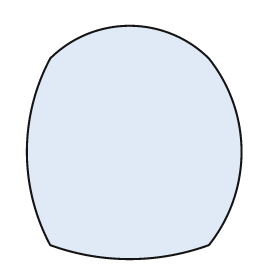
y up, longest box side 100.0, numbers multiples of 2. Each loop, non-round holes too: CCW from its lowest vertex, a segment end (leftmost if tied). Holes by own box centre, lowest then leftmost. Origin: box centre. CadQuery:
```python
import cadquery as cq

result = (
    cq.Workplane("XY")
    .moveTo(-36.0, -44.0)
    .threePointArc((-2.0, -50.0), (32.0, -44.0))
    .threePointArc((46.0, -4.0), (32.0, 36.0))
    .threePointArc((-2.0, 50.0), (-36.0, 36.0))
    .threePointArc((-46.0, -4.0), (-36.0, -44.0))
    .close()
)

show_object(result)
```